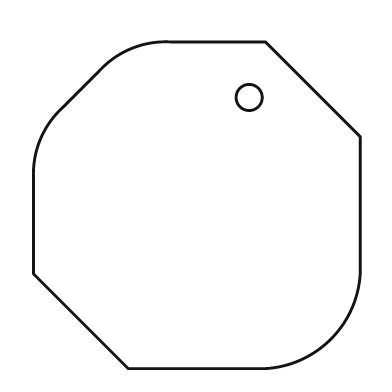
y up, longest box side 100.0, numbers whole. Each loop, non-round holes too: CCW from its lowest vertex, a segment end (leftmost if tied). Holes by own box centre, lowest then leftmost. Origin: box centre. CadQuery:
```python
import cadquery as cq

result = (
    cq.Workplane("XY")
    .moveTo(-21.0, -50.0)
    .lineTo(21.0, -50.0)
    .threePointArc((41.0, -41.0), (50.0, -21.0))
    .lineTo(50.0, 21.0)
    .lineTo(21.0, 50.0)
    .lineTo(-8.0, 50.0)
    .threePointArc((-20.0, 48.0), (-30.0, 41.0))
    .lineTo(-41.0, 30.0)
    .threePointArc((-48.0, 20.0), (-50.0, 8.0))
    .lineTo(-50.0, -21.0)
    .close()
    .moveTo(16.0, 33.0)
    .circle(4.0)
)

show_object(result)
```